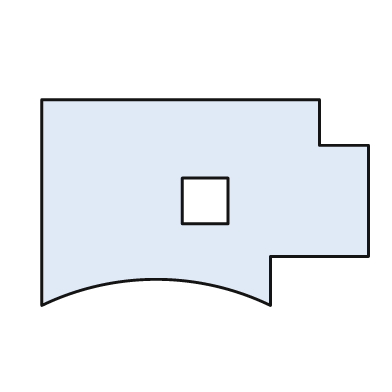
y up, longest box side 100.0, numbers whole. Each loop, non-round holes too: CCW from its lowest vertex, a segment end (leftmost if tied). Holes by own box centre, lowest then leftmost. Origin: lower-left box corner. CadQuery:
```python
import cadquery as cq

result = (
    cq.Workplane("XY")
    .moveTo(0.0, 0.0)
    .threePointArc((35.0, 8.0), (70.0, 0.0))
    .lineTo(70.0, 15.0)
    .lineTo(100.0, 15.0)
    .lineTo(100.0, 49.0)
    .lineTo(85.0, 49.0)
    .lineTo(85.0, 63.0)
    .lineTo(0.0, 63.0)
    .close()
    .moveTo(43.0, 25.0)
    .lineTo(57.0, 25.0)
    .lineTo(57.0, 39.0)
    .lineTo(43.0, 39.0)
    .close()
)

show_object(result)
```